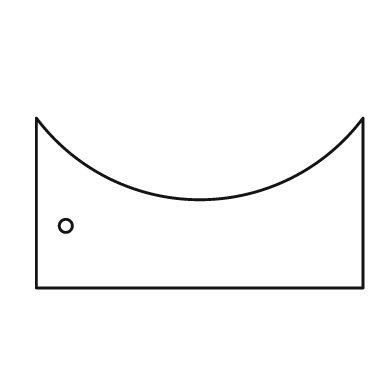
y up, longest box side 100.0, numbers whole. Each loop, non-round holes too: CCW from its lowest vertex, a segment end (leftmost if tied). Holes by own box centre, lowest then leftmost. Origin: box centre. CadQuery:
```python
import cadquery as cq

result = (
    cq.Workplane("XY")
    .moveTo(-50.0, -26.0)
    .lineTo(50.0, -26.0)
    .lineTo(50.0, 26.0)
    .threePointArc((0.0, 1.0), (-50.0, 26.0))
    .close()
    .moveTo(-41.0, -7.0)
    .circle(2.0)
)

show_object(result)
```